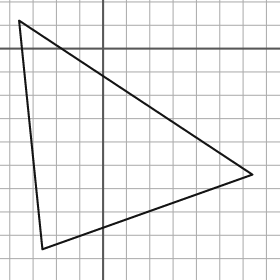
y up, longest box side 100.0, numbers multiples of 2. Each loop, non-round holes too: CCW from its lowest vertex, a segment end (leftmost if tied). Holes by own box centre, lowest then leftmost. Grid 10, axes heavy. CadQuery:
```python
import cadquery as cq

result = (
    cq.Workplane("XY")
    .moveTo(-26.0, -86.0)
    .lineTo(64.0, -54.0)
    .lineTo(-36.0, 12.0)
    .close()
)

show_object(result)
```